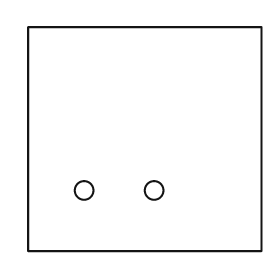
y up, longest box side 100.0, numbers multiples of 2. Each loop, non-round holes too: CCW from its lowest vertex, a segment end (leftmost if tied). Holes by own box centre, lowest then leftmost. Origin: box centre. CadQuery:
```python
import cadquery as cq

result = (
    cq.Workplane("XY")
    .moveTo(-50.0, -48.0)
    .lineTo(50.0, -48.0)
    .lineTo(50.0, 48.0)
    .lineTo(-50.0, 48.0)
    .close()
    .moveTo(-26.0, -22.0)
    .circle(4.0)
    .moveTo(4.0, -22.0)
    .circle(4.0)
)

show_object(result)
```